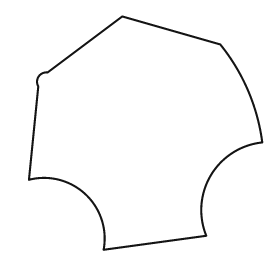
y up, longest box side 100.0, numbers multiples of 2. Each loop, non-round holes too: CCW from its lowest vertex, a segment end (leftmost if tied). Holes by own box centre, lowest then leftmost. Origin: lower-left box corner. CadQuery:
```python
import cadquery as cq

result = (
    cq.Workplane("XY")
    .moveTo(32.0, 0.0)
    .lineTo(76.0, 6.0)
    .threePointArc((78.0, 32.0), (100.0, 46.0))
    .threePointArc((94.0, 68.0), (82.0, 88.0))
    .lineTo(40.0, 100.0)
    .lineTo(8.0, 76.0)
    .threePointArc((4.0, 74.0), (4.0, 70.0))
    .lineTo(0.0, 30.0)
    .threePointArc((24.0, 24.0), (32.0, 0.0))
    .close()
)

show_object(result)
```